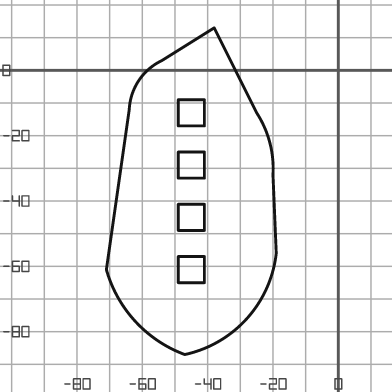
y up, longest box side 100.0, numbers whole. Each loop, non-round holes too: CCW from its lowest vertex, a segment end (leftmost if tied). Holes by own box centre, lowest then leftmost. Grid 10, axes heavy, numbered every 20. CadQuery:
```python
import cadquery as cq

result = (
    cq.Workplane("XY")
    .moveTo(-47.0, -87.0)
    .threePointArc((-28.0, -76.0), (-19.0, -56.0))
    .lineTo(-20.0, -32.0)
    .threePointArc((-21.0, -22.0), (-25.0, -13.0))
    .lineTo(-38.0, 13.0)
    .lineTo(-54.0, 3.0)
    .threePointArc((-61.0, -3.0), (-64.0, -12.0))
    .lineTo(-71.0, -61.0)
    .threePointArc((-62.0, -77.0), (-47.0, -87.0))
    .close()
    .moveTo(-49.0, -65.0)
    .lineTo(-41.0, -65.0)
    .lineTo(-41.0, -57.0)
    .lineTo(-49.0, -57.0)
    .close()
    .moveTo(-49.0, -49.0)
    .lineTo(-41.0, -49.0)
    .lineTo(-41.0, -41.0)
    .lineTo(-49.0, -41.0)
    .close()
    .moveTo(-49.0, -33.0)
    .lineTo(-41.0, -33.0)
    .lineTo(-41.0, -25.0)
    .lineTo(-49.0, -25.0)
    .close()
    .moveTo(-49.0, -17.0)
    .lineTo(-41.0, -17.0)
    .lineTo(-41.0, -9.0)
    .lineTo(-49.0, -9.0)
    .close()
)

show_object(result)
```